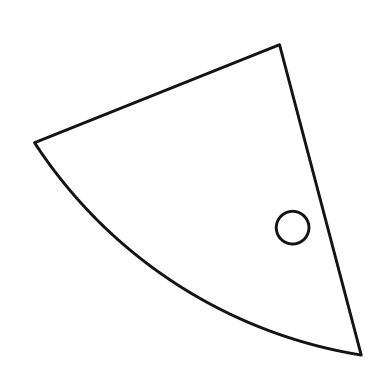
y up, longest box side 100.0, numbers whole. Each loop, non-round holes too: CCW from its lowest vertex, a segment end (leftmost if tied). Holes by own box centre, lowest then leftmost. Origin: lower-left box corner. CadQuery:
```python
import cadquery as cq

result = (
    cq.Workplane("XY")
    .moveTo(100.0, 0.0)
    .lineTo(75.0, 95.0)
    .lineTo(0.0, 65.0)
    .threePointArc((43.0, 22.0), (100.0, 0.0))
    .close()
    .moveTo(79.0, 39.0)
    .circle(5.0)
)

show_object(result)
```